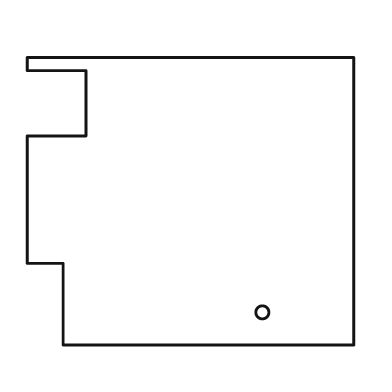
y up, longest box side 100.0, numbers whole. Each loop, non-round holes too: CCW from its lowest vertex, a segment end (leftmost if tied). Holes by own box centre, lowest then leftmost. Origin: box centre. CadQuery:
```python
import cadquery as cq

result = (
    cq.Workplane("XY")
    .moveTo(-39.0, -44.0)
    .lineTo(50.0, -44.0)
    .lineTo(50.0, 44.0)
    .lineTo(-50.0, 44.0)
    .lineTo(-50.0, 40.0)
    .lineTo(-32.0, 40.0)
    .lineTo(-32.0, 20.0)
    .lineTo(-50.0, 20.0)
    .lineTo(-50.0, -19.0)
    .lineTo(-39.0, -19.0)
    .close()
    .moveTo(22.0, -34.0)
    .circle(2.0)
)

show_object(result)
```